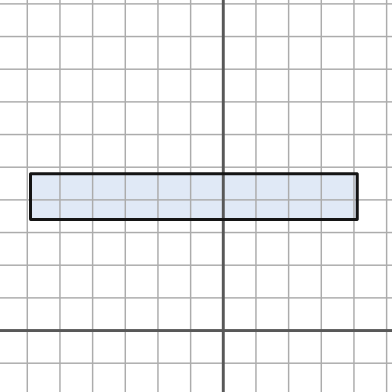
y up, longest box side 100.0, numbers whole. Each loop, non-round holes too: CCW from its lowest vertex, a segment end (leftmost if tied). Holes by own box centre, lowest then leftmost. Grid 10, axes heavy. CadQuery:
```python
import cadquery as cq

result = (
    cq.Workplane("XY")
    .moveTo(-59.0, 34.0)
    .lineTo(41.0, 34.0)
    .lineTo(41.0, 48.0)
    .lineTo(-59.0, 48.0)
    .close()
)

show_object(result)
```